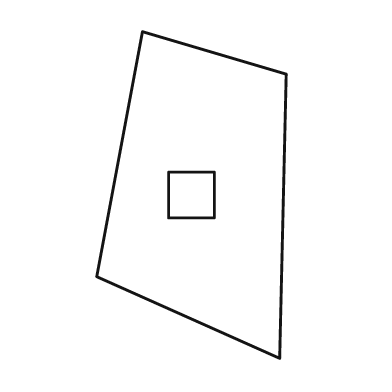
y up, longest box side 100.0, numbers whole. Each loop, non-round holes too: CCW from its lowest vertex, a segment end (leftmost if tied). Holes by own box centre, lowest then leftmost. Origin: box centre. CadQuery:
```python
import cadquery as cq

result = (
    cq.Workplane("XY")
    .moveTo(27.0, -50.0)
    .lineTo(29.0, 37.0)
    .lineTo(-15.0, 50.0)
    .lineTo(-29.0, -25.0)
    .close()
    .moveTo(-7.0, -7.0)
    .lineTo(7.0, -7.0)
    .lineTo(7.0, 7.0)
    .lineTo(-7.0, 7.0)
    .close()
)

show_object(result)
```